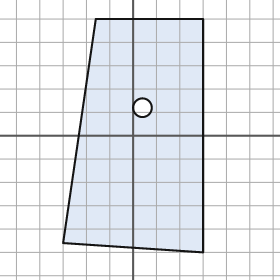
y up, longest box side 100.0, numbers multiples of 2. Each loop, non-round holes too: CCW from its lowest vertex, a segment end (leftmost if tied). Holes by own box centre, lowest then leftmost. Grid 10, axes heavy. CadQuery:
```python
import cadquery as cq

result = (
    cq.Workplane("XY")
    .moveTo(30.0, -50.0)
    .lineTo(30.0, 50.0)
    .lineTo(-16.0, 50.0)
    .lineTo(-30.0, -46.0)
    .close()
    .moveTo(4.0, 12.0)
    .circle(4.0)
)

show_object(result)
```